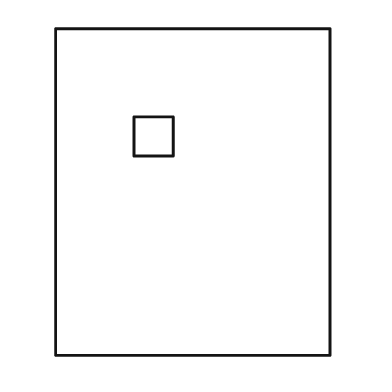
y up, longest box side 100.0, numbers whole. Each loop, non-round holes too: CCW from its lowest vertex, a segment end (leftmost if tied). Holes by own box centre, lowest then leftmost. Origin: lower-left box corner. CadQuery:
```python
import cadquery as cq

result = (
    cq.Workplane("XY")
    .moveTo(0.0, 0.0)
    .lineTo(84.0, 0.0)
    .lineTo(84.0, 100.0)
    .lineTo(0.0, 100.0)
    .close()
    .moveTo(24.0, 61.0)
    .lineTo(36.0, 61.0)
    .lineTo(36.0, 73.0)
    .lineTo(24.0, 73.0)
    .close()
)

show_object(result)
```